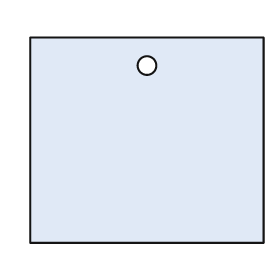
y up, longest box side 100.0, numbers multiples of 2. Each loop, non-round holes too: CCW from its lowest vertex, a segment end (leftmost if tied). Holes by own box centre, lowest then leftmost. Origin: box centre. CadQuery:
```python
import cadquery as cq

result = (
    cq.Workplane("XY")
    .moveTo(-50.0, -44.0)
    .lineTo(50.0, -44.0)
    .lineTo(50.0, 44.0)
    .lineTo(-50.0, 44.0)
    .close()
    .moveTo(0.0, 32.0)
    .circle(4.0)
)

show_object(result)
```